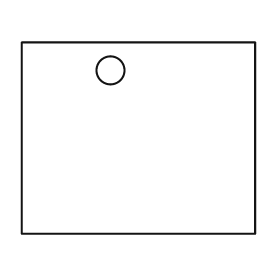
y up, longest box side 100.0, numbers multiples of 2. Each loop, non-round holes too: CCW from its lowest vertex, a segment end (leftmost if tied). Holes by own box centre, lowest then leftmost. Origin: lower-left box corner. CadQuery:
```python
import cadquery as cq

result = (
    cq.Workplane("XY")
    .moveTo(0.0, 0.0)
    .lineTo(100.0, 0.0)
    .lineTo(100.0, 82.0)
    .lineTo(0.0, 82.0)
    .close()
    .moveTo(38.0, 70.0)
    .circle(6.0)
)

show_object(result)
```